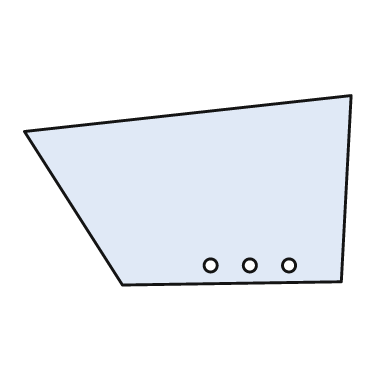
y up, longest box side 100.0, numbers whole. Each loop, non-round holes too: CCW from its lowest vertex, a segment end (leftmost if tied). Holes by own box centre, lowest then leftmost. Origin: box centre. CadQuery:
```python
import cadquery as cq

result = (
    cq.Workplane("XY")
    .moveTo(-20.0, -29.0)
    .lineTo(47.0, -28.0)
    .lineTo(50.0, 29.0)
    .lineTo(-50.0, 18.0)
    .close()
    .moveTo(7.0, -23.0)
    .circle(2.0)
    .moveTo(19.0, -23.0)
    .circle(2.0)
    .moveTo(31.0, -23.0)
    .circle(2.0)
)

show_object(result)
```